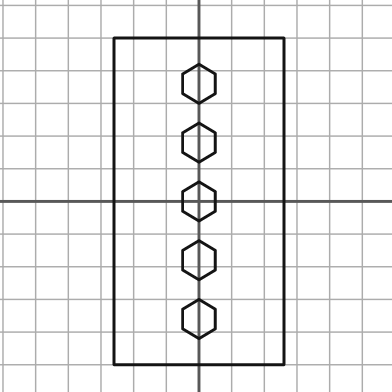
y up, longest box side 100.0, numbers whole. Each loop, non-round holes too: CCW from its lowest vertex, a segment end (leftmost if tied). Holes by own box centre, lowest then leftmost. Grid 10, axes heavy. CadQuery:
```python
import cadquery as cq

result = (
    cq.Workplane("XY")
    .moveTo(-26.0, -50.0)
    .lineTo(26.0, -50.0)
    .lineTo(26.0, 50.0)
    .lineTo(-26.0, 50.0)
    .close()
    .moveTo(0.0, -42.0)
    .lineTo(5.0, -39.0)
    .lineTo(5.0, -33.0)
    .lineTo(0.0, -30.0)
    .lineTo(-5.0, -33.0)
    .lineTo(-5.0, -39.0)
    .close()
    .moveTo(0.0, -24.0)
    .lineTo(5.0, -21.0)
    .lineTo(5.0, -15.0)
    .lineTo(0.0, -12.0)
    .lineTo(-5.0, -15.0)
    .lineTo(-5.0, -21.0)
    .close()
    .moveTo(0.0, -6.0)
    .lineTo(5.0, -3.0)
    .lineTo(5.0, 3.0)
    .lineTo(0.0, 6.0)
    .lineTo(-5.0, 3.0)
    .lineTo(-5.0, -3.0)
    .close()
    .moveTo(0.0, 12.0)
    .lineTo(5.0, 15.0)
    .lineTo(5.0, 21.0)
    .lineTo(0.0, 24.0)
    .lineTo(-5.0, 21.0)
    .lineTo(-5.0, 15.0)
    .close()
    .moveTo(0.0, 30.0)
    .lineTo(5.0, 33.0)
    .lineTo(5.0, 39.0)
    .lineTo(0.0, 42.0)
    .lineTo(-5.0, 39.0)
    .lineTo(-5.0, 33.0)
    .close()
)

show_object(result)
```